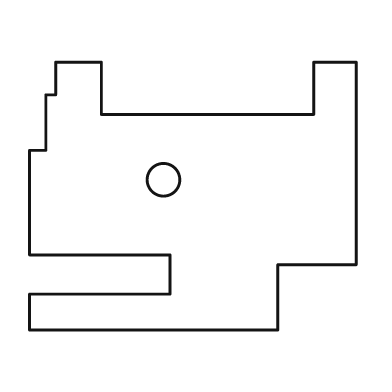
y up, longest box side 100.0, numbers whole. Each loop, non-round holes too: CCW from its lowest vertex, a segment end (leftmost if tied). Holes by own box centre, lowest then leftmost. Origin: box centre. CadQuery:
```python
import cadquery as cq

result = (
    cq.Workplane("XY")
    .moveTo(-50.0, -41.0)
    .lineTo(26.0, -41.0)
    .lineTo(26.0, -21.0)
    .lineTo(50.0, -21.0)
    .lineTo(50.0, 41.0)
    .lineTo(37.0, 41.0)
    .lineTo(37.0, 25.0)
    .lineTo(-28.0, 25.0)
    .lineTo(-28.0, 41.0)
    .lineTo(-42.0, 41.0)
    .lineTo(-42.0, 31.0)
    .lineTo(-45.0, 31.0)
    .lineTo(-45.0, 14.0)
    .lineTo(-50.0, 14.0)
    .lineTo(-50.0, -18.0)
    .lineTo(-7.0, -18.0)
    .lineTo(-7.0, -30.0)
    .lineTo(-50.0, -30.0)
    .close()
    .moveTo(-9.0, 5.0)
    .circle(5.0)
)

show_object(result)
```